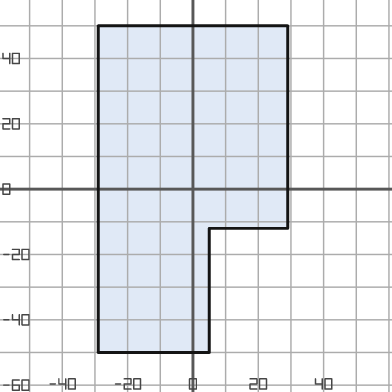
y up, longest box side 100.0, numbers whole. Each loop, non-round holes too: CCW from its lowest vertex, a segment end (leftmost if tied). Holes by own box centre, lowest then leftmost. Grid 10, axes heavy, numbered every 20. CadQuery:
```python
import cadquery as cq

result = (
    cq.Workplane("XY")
    .moveTo(-29.0, -50.0)
    .lineTo(5.0, -50.0)
    .lineTo(5.0, -12.0)
    .lineTo(29.0, -12.0)
    .lineTo(29.0, 50.0)
    .lineTo(-29.0, 50.0)
    .close()
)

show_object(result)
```